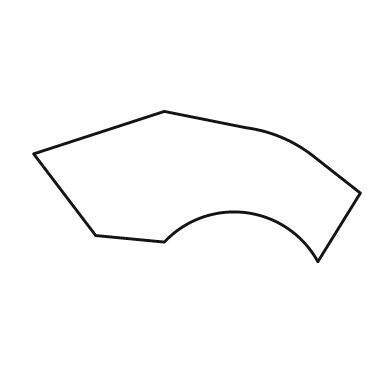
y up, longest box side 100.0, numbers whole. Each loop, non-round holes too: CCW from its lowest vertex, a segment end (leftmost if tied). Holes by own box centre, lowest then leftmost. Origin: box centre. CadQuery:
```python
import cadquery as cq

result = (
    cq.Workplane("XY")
    .moveTo(37.0, -23.0)
    .lineTo(50.0, -2.0)
    .lineTo(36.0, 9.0)
    .threePointArc((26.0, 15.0), (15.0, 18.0))
    .lineTo(-10.0, 23.0)
    .lineTo(-50.0, 10.0)
    .lineTo(-31.0, -15.0)
    .lineTo(-10.0, -17.0)
    .threePointArc((15.0, -8.0), (37.0, -23.0))
    .close()
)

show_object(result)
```